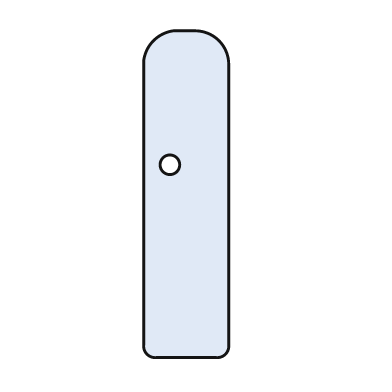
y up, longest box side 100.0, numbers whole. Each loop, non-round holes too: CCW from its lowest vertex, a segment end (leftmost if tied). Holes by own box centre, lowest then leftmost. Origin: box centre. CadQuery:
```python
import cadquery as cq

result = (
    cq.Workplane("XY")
    .moveTo(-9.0, -50.0)
    .lineTo(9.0, -50.0)
    .threePointArc((12.0, -49.0), (13.0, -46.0))
    .lineTo(13.0, 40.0)
    .threePointArc((10.0, 47.0), (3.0, 50.0))
    .lineTo(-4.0, 50.0)
    .threePointArc((-10.0, 47.0), (-13.0, 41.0))
    .lineTo(-13.0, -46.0)
    .threePointArc((-12.0, -49.0), (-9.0, -50.0))
    .close()
    .moveTo(-5.0, 9.0)
    .circle(3.0)
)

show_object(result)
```